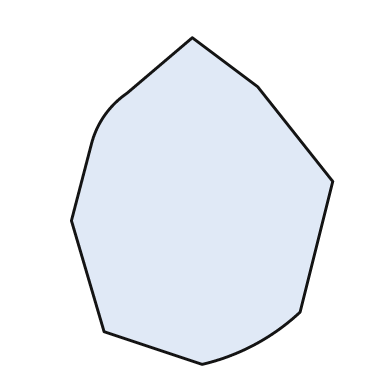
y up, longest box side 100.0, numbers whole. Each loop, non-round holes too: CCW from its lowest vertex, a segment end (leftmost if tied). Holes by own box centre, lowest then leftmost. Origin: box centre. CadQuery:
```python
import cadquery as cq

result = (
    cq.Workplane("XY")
    .moveTo(0.0, -50.0)
    .threePointArc((16.0, -44.0), (30.0, -34.0))
    .lineTo(40.0, 6.0)
    .lineTo(17.0, 35.0)
    .lineTo(-3.0, 50.0)
    .lineTo(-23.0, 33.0)
    .threePointArc((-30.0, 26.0), (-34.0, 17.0))
    .lineTo(-40.0, -6.0)
    .lineTo(-30.0, -40.0)
    .close()
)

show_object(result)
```